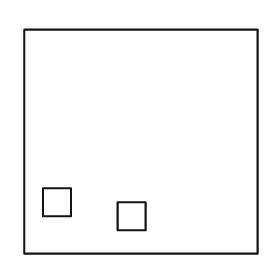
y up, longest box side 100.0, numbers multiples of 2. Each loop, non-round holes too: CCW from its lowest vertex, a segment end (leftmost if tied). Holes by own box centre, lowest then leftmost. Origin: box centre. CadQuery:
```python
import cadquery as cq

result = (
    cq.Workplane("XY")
    .moveTo(-50.0, -48.0)
    .lineTo(50.0, -48.0)
    .lineTo(50.0, 48.0)
    .lineTo(-50.0, 48.0)
    .close()
    .moveTo(-10.0, -38.0)
    .lineTo(2.0, -38.0)
    .lineTo(2.0, -26.0)
    .lineTo(-10.0, -26.0)
    .close()
    .moveTo(-42.0, -32.0)
    .lineTo(-30.0, -32.0)
    .lineTo(-30.0, -20.0)
    .lineTo(-42.0, -20.0)
    .close()
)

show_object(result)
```